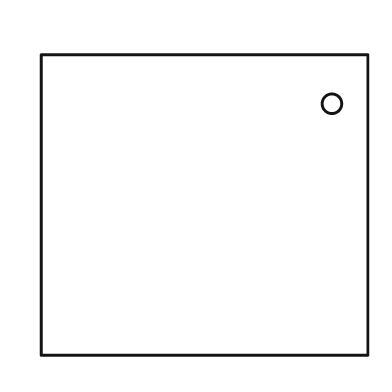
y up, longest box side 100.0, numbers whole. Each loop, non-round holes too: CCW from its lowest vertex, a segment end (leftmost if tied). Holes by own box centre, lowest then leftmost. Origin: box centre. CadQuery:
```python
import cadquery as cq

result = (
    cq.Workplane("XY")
    .moveTo(-50.0, -46.0)
    .lineTo(50.0, -46.0)
    .lineTo(50.0, 46.0)
    .lineTo(-50.0, 46.0)
    .close()
    .moveTo(39.0, 31.0)
    .circle(3.0)
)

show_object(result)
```